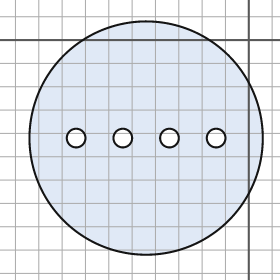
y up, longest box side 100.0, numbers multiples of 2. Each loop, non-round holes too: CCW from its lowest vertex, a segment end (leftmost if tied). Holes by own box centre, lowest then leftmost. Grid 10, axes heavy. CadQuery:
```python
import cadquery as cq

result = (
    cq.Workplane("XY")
    .moveTo(-44.0, -42.0)
    .circle(50.0)
    .moveTo(-74.0, -42.0)
    .circle(4.0)
    .moveTo(-54.0, -42.0)
    .circle(4.0)
    .moveTo(-34.0, -42.0)
    .circle(4.0)
    .moveTo(-14.0, -42.0)
    .circle(4.0)
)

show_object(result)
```